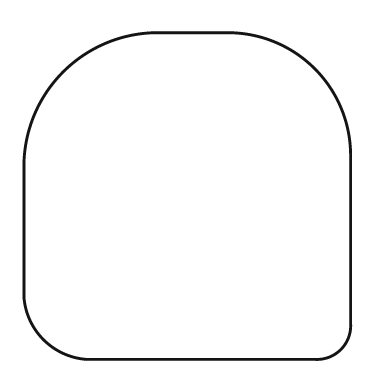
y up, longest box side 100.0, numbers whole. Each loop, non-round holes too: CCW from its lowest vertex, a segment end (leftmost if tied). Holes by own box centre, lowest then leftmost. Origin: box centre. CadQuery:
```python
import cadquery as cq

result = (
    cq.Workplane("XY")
    .moveTo(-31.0, -50.0)
    .lineTo(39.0, -50.0)
    .threePointArc((47.0, -47.0), (50.0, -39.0))
    .lineTo(50.0, 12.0)
    .threePointArc((39.0, 39.0), (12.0, 50.0))
    .lineTo(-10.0, 50.0)
    .threePointArc((-38.0, 38.0), (-50.0, 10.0))
    .lineTo(-50.0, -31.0)
    .threePointArc((-44.0, -44.0), (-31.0, -50.0))
    .close()
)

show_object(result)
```